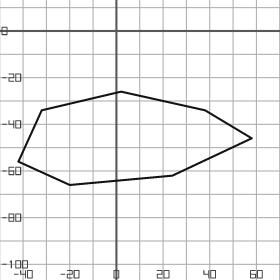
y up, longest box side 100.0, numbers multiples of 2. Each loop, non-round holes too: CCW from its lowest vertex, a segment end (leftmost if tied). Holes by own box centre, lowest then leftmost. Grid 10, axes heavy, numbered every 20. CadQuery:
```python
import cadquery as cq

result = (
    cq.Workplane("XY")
    .moveTo(-20.0, -66.0)
    .lineTo(24.0, -62.0)
    .lineTo(58.0, -46.0)
    .lineTo(38.0, -34.0)
    .lineTo(2.0, -26.0)
    .lineTo(-32.0, -34.0)
    .lineTo(-42.0, -56.0)
    .close()
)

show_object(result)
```